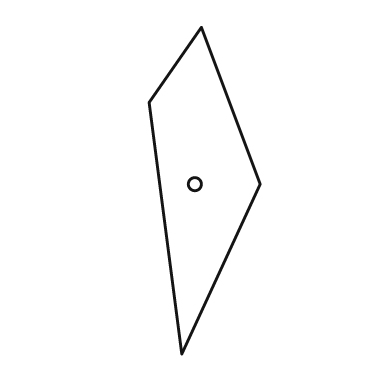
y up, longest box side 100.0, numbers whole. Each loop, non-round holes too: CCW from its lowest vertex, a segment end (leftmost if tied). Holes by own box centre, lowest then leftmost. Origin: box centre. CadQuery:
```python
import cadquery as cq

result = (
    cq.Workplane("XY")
    .moveTo(-7.0, -50.0)
    .lineTo(17.0, 2.0)
    .lineTo(-1.0, 50.0)
    .lineTo(-17.0, 27.0)
    .close()
    .moveTo(-3.0, 2.0)
    .circle(2.0)
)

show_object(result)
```